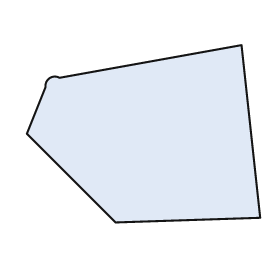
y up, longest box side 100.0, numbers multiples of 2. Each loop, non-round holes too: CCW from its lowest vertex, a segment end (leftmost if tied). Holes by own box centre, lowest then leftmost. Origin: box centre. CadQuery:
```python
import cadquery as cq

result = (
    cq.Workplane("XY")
    .moveTo(-12.0, -38.0)
    .lineTo(50.0, -36.0)
    .lineTo(42.0, 38.0)
    .lineTo(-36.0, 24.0)
    .threePointArc((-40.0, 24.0), (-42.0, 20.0))
    .lineTo(-50.0, 0.0)
    .close()
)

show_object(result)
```